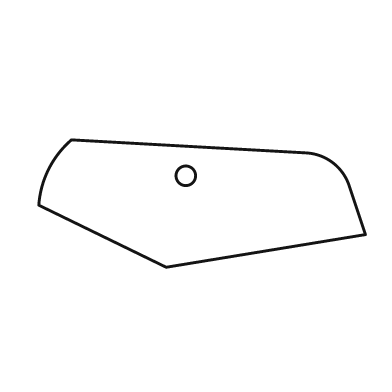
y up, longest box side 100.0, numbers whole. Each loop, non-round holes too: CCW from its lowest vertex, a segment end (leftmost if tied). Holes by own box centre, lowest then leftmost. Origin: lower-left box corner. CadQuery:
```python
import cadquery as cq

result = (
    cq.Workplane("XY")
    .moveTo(39.0, 0.0)
    .lineTo(100.0, 10.0)
    .lineTo(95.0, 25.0)
    .threePointArc((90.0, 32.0), (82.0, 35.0))
    .lineTo(10.0, 39.0)
    .threePointArc((3.0, 30.0), (0.0, 19.0))
    .close()
    .moveTo(45.0, 28.0)
    .circle(3.0)
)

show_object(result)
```